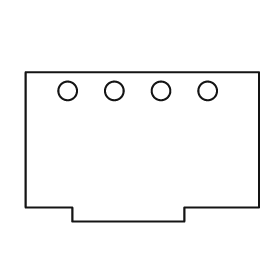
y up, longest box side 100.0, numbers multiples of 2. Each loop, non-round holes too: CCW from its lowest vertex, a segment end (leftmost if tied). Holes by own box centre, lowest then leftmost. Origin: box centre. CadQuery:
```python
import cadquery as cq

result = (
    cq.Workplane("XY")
    .moveTo(-30.0, -32.0)
    .lineTo(18.0, -32.0)
    .lineTo(18.0, -26.0)
    .lineTo(50.0, -26.0)
    .lineTo(50.0, 32.0)
    .lineTo(-50.0, 32.0)
    .lineTo(-50.0, -26.0)
    .lineTo(-30.0, -26.0)
    .close()
    .moveTo(-32.0, 24.0)
    .circle(4.0)
    .moveTo(-12.0, 24.0)
    .circle(4.0)
    .moveTo(8.0, 24.0)
    .circle(4.0)
    .moveTo(28.0, 24.0)
    .circle(4.0)
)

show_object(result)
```